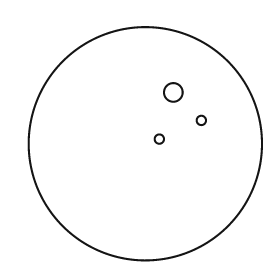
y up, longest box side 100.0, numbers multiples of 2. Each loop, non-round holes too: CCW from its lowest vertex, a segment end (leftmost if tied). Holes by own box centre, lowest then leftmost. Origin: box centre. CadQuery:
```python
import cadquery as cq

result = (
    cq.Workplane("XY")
    .moveTo(0.0, 0.0)
    .circle(50.0)
    .moveTo(6.0, 2.0)
    .circle(2.0)
    .moveTo(24.0, 10.0)
    .circle(2.0)
    .moveTo(12.0, 22.0)
    .circle(4.0)
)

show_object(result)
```